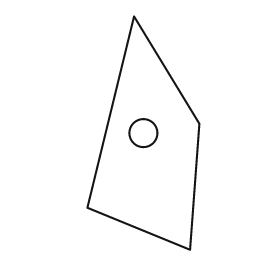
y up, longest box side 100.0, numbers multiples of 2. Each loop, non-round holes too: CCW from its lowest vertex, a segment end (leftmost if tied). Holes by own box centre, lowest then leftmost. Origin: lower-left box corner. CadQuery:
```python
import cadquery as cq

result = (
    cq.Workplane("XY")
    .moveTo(44.0, 0.0)
    .lineTo(48.0, 54.0)
    .lineTo(20.0, 100.0)
    .lineTo(0.0, 18.0)
    .close()
    .moveTo(24.0, 50.0)
    .circle(6.0)
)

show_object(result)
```